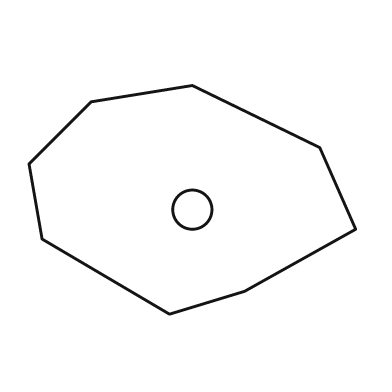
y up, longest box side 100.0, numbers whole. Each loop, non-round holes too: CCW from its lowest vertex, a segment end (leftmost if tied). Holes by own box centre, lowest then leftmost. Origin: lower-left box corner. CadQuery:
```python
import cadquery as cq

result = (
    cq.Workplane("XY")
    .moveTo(43.0, 0.0)
    .lineTo(66.0, 7.0)
    .lineTo(100.0, 26.0)
    .lineTo(89.0, 51.0)
    .lineTo(50.0, 70.0)
    .lineTo(19.0, 65.0)
    .lineTo(0.0, 46.0)
    .lineTo(4.0, 23.0)
    .close()
    .moveTo(50.0, 32.0)
    .circle(6.0)
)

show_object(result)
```